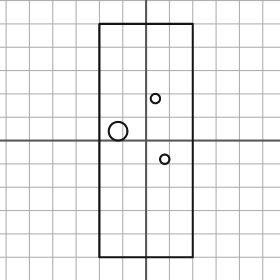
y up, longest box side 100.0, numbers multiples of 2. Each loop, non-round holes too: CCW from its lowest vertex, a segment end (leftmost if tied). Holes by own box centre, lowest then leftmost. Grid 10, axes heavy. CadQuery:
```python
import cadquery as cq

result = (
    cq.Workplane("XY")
    .moveTo(-20.0, -50.0)
    .lineTo(20.0, -50.0)
    .lineTo(20.0, 50.0)
    .lineTo(-20.0, 50.0)
    .close()
    .moveTo(8.0, -8.0)
    .circle(2.0)
    .moveTo(-12.0, 4.0)
    .circle(4.0)
    .moveTo(4.0, 18.0)
    .circle(2.0)
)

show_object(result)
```